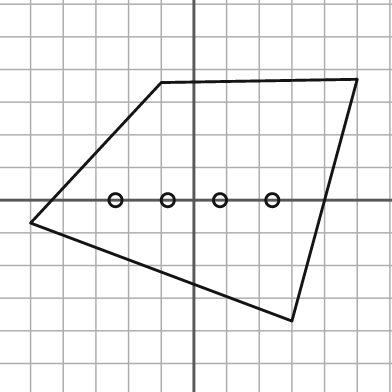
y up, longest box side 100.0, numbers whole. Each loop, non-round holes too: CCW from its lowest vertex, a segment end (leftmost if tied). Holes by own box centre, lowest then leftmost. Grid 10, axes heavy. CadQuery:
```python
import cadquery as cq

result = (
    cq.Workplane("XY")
    .moveTo(30.0, -37.0)
    .lineTo(50.0, 37.0)
    .lineTo(-10.0, 36.0)
    .lineTo(-50.0, -7.0)
    .close()
    .moveTo(-24.0, 0.0)
    .circle(2.0)
    .moveTo(-8.0, 0.0)
    .circle(2.0)
    .moveTo(8.0, 0.0)
    .circle(2.0)
    .moveTo(24.0, 0.0)
    .circle(2.0)
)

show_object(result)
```